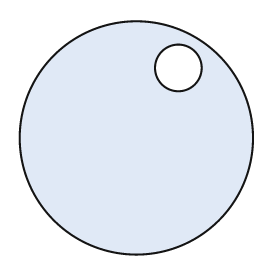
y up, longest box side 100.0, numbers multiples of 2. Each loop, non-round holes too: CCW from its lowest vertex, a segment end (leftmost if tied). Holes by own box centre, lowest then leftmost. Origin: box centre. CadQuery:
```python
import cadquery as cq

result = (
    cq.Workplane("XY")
    .moveTo(0.0, 0.0)
    .circle(50.0)
    .moveTo(18.0, 30.0)
    .circle(10.0)
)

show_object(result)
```